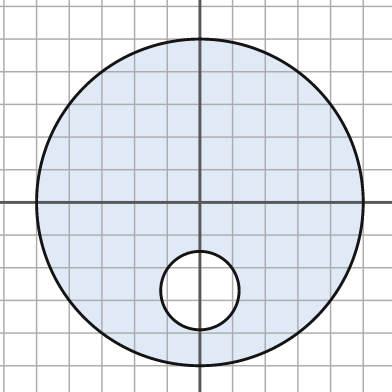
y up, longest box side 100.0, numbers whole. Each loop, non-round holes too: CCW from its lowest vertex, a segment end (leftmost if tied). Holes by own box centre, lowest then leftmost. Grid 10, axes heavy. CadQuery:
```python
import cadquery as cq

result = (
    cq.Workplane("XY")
    .moveTo(0.0, 0.0)
    .circle(50.0)
    .moveTo(0.0, -27.0)
    .circle(12.0)
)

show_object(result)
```